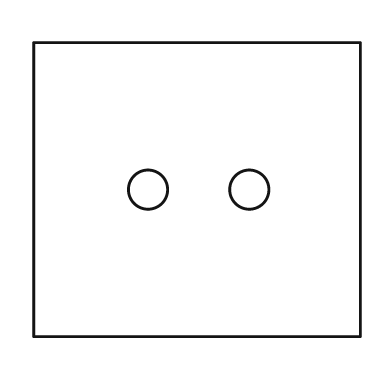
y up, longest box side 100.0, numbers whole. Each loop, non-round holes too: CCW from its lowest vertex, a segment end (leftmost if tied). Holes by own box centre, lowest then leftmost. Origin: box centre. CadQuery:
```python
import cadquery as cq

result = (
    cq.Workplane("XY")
    .moveTo(-50.0, -45.0)
    .lineTo(50.0, -45.0)
    .lineTo(50.0, 45.0)
    .lineTo(-50.0, 45.0)
    .close()
    .moveTo(-15.0, 0.0)
    .circle(6.0)
    .moveTo(16.0, 0.0)
    .circle(6.0)
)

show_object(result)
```